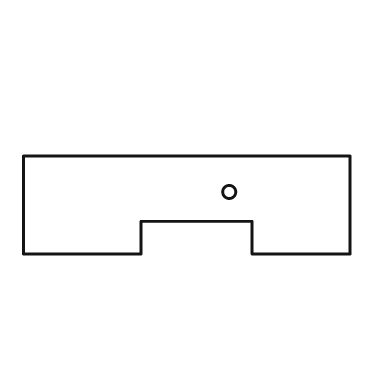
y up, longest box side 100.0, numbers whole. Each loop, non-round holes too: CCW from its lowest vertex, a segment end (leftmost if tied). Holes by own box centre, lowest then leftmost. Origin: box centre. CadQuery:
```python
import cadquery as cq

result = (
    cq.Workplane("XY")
    .moveTo(-50.0, -15.0)
    .lineTo(-14.0, -15.0)
    .lineTo(-14.0, -5.0)
    .lineTo(20.0, -5.0)
    .lineTo(20.0, -15.0)
    .lineTo(50.0, -15.0)
    .lineTo(50.0, 15.0)
    .lineTo(-50.0, 15.0)
    .close()
    .moveTo(13.0, 4.0)
    .circle(2.0)
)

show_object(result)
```